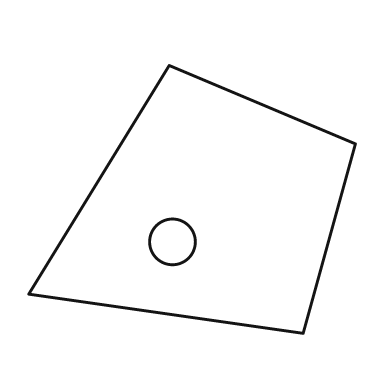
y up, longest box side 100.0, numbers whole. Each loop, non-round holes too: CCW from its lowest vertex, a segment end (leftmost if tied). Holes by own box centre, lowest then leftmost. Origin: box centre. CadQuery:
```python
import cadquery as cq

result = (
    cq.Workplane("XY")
    .moveTo(34.0, -41.0)
    .lineTo(50.0, 17.0)
    .lineTo(-7.0, 41.0)
    .lineTo(-50.0, -29.0)
    .close()
    .moveTo(-6.0, -13.0)
    .circle(7.0)
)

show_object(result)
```